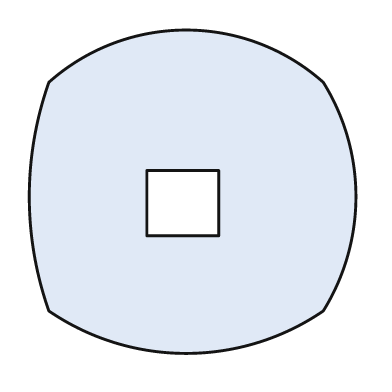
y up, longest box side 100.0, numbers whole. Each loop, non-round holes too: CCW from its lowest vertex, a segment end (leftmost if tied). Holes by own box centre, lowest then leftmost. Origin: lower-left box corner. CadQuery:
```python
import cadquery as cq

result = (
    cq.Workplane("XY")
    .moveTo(6.0, 13.0)
    .threePointArc((48.0, 0.0), (90.0, 13.0))
    .threePointArc((100.0, 48.0), (90.0, 83.0))
    .threePointArc((48.0, 99.0), (6.0, 83.0))
    .threePointArc((0.0, 48.0), (6.0, 13.0))
    .close()
    .moveTo(36.0, 36.0)
    .lineTo(58.0, 36.0)
    .lineTo(58.0, 56.0)
    .lineTo(36.0, 56.0)
    .close()
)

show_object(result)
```